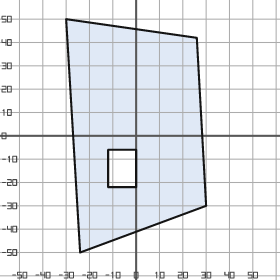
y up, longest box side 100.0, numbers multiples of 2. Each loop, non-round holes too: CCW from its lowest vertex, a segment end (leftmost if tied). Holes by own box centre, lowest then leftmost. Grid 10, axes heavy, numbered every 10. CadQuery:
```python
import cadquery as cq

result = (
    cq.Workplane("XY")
    .moveTo(-24.0, -50.0)
    .lineTo(30.0, -30.0)
    .lineTo(26.0, 42.0)
    .lineTo(-30.0, 50.0)
    .close()
    .moveTo(-12.0, -22.0)
    .lineTo(0.0, -22.0)
    .lineTo(0.0, -6.0)
    .lineTo(-12.0, -6.0)
    .close()
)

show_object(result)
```